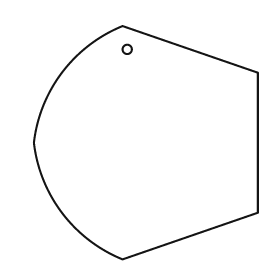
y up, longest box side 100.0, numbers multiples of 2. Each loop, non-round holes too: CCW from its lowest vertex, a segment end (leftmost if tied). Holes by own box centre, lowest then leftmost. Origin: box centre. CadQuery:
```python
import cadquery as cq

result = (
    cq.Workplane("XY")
    .moveTo(-10.0, -50.0)
    .lineTo(48.0, -30.0)
    .lineTo(48.0, 30.0)
    .lineTo(-10.0, 50.0)
    .threePointArc((-36.0, 30.0), (-48.0, 0.0))
    .threePointArc((-36.0, -30.0), (-10.0, -50.0))
    .close()
    .moveTo(-8.0, 40.0)
    .circle(2.0)
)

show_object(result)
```